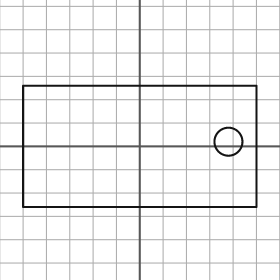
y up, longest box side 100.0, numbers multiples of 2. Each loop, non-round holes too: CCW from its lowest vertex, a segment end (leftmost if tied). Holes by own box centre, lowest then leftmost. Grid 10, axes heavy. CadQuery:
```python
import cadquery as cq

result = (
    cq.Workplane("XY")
    .moveTo(-50.0, -26.0)
    .lineTo(50.0, -26.0)
    .lineTo(50.0, 26.0)
    .lineTo(-50.0, 26.0)
    .close()
    .moveTo(38.0, 2.0)
    .circle(6.0)
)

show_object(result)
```